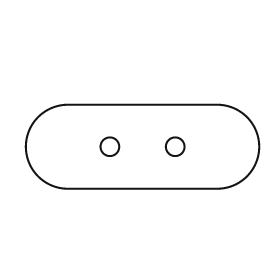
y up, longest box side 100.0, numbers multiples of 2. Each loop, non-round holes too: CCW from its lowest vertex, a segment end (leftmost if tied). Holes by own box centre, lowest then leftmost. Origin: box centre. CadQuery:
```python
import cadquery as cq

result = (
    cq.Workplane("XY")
    .moveTo(-32.0, -18.0)
    .lineTo(32.0, -18.0)
    .threePointArc((50.0, 0.0), (32.0, 18.0))
    .lineTo(-32.0, 18.0)
    .threePointArc((-50.0, 0.0), (-32.0, -18.0))
    .close()
    .moveTo(-14.0, 0.0)
    .circle(4.0)
    .moveTo(14.0, 0.0)
    .circle(4.0)
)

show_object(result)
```